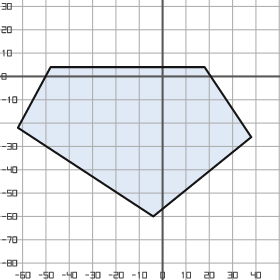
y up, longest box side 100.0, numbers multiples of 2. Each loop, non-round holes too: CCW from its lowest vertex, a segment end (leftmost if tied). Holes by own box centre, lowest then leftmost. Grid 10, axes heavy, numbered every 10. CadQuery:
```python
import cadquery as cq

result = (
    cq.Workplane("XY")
    .moveTo(-4.0, -60.0)
    .lineTo(38.0, -26.0)
    .lineTo(18.0, 4.0)
    .lineTo(-48.0, 4.0)
    .lineTo(-62.0, -22.0)
    .close()
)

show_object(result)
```